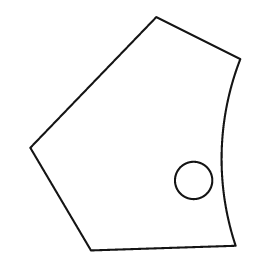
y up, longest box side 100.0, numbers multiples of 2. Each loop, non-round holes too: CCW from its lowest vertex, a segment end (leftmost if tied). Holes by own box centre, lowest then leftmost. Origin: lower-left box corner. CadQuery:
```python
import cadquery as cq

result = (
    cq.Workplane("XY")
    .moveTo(26.0, 0.0)
    .lineTo(88.0, 2.0)
    .threePointArc((82.0, 42.0), (90.0, 82.0))
    .lineTo(54.0, 100.0)
    .lineTo(0.0, 44.0)
    .close()
    .moveTo(70.0, 30.0)
    .circle(8.0)
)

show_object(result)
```